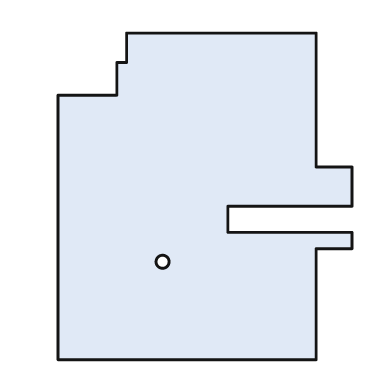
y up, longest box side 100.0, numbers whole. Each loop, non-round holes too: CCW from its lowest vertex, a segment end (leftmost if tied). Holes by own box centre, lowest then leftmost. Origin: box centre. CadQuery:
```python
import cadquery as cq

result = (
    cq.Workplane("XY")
    .moveTo(-45.0, -50.0)
    .lineTo(34.0, -50.0)
    .lineTo(34.0, -16.0)
    .lineTo(45.0, -16.0)
    .lineTo(45.0, -11.0)
    .lineTo(7.0, -11.0)
    .lineTo(7.0, -3.0)
    .lineTo(45.0, -3.0)
    .lineTo(45.0, 9.0)
    .lineTo(34.0, 9.0)
    .lineTo(34.0, 50.0)
    .lineTo(-24.0, 50.0)
    .lineTo(-24.0, 41.0)
    .lineTo(-27.0, 41.0)
    .lineTo(-27.0, 31.0)
    .lineTo(-45.0, 31.0)
    .close()
    .moveTo(-13.0, -20.0)
    .circle(2.0)
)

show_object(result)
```